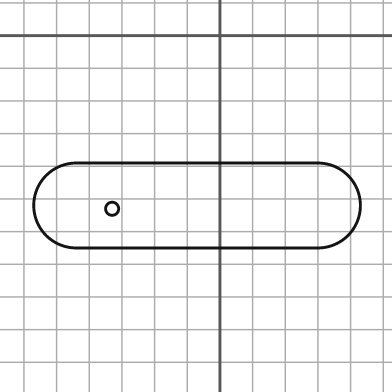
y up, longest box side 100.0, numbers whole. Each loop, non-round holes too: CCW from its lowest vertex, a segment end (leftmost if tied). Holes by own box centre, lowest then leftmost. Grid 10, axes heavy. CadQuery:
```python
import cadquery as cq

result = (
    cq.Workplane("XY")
    .moveTo(-44.0, -65.0)
    .lineTo(30.0, -65.0)
    .threePointArc((43.0, -52.0), (30.0, -39.0))
    .lineTo(-44.0, -39.0)
    .threePointArc((-57.0, -52.0), (-44.0, -65.0))
    .close()
    .moveTo(-33.0, -53.0)
    .circle(2.0)
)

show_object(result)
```